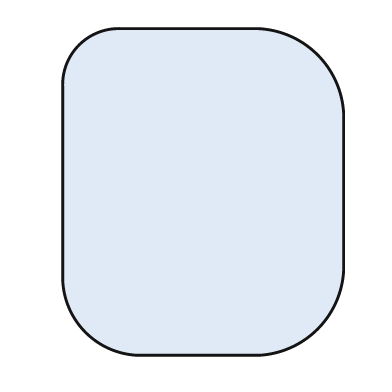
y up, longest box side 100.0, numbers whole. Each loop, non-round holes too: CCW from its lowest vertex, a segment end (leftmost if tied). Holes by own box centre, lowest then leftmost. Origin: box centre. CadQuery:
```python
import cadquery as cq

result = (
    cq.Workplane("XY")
    .moveTo(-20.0, -50.0)
    .lineTo(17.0, -50.0)
    .threePointArc((35.0, -42.0), (43.0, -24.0))
    .lineTo(43.0, 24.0)
    .threePointArc((35.0, 42.0), (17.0, 50.0))
    .lineTo(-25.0, 50.0)
    .threePointArc((-38.0, 45.0), (-43.0, 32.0))
    .lineTo(-43.0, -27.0)
    .threePointArc((-36.0, -43.0), (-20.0, -50.0))
    .close()
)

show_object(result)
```